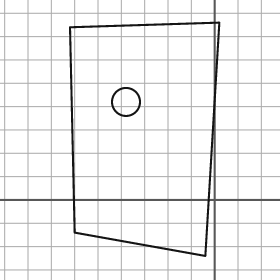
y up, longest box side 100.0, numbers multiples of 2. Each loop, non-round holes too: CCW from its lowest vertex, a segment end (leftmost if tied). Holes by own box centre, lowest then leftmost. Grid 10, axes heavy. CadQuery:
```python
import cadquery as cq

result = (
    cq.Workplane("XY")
    .moveTo(-4.0, -24.0)
    .lineTo(2.0, 76.0)
    .lineTo(-62.0, 74.0)
    .lineTo(-60.0, -14.0)
    .close()
    .moveTo(-38.0, 42.0)
    .circle(6.0)
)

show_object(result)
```